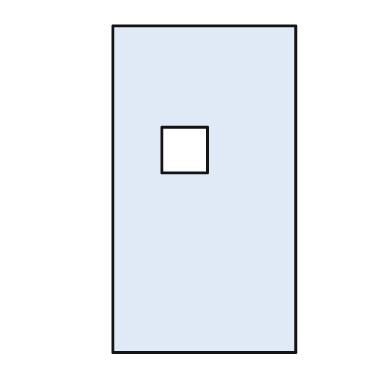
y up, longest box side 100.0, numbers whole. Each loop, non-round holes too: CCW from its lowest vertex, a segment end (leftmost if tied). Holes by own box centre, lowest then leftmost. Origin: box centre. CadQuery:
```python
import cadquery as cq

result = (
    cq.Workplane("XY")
    .moveTo(-28.0, -50.0)
    .lineTo(28.0, -50.0)
    .lineTo(28.0, 50.0)
    .lineTo(-28.0, 50.0)
    .close()
    .moveTo(-13.0, 5.0)
    .lineTo(1.0, 5.0)
    .lineTo(1.0, 19.0)
    .lineTo(-13.0, 19.0)
    .close()
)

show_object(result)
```